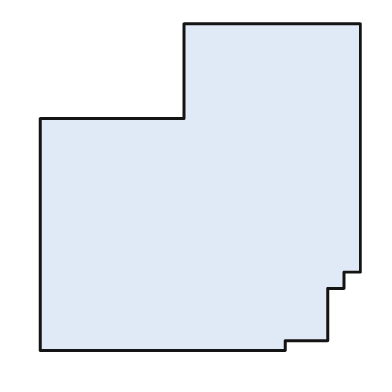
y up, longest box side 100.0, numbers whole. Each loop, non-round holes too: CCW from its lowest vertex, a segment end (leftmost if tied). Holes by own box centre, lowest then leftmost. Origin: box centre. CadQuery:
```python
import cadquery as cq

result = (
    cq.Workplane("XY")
    .moveTo(-49.0, -50.0)
    .lineTo(26.0, -50.0)
    .lineTo(26.0, -47.0)
    .lineTo(39.0, -47.0)
    .lineTo(39.0, -31.0)
    .lineTo(44.0, -31.0)
    .lineTo(44.0, -26.0)
    .lineTo(49.0, -26.0)
    .lineTo(49.0, 50.0)
    .lineTo(-5.0, 50.0)
    .lineTo(-5.0, 21.0)
    .lineTo(-49.0, 21.0)
    .close()
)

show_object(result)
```